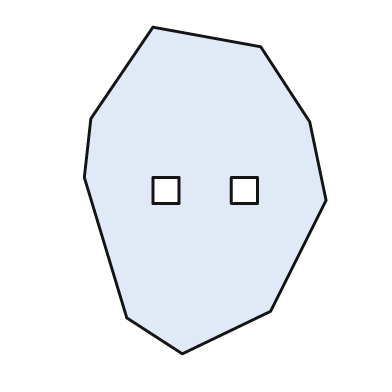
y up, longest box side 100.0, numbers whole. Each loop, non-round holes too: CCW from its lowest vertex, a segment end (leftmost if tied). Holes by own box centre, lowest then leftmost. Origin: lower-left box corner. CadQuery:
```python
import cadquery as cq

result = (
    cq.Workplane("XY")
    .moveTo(30.0, 0.0)
    .lineTo(57.0, 13.0)
    .lineTo(74.0, 47.0)
    .lineTo(69.0, 71.0)
    .lineTo(54.0, 94.0)
    .lineTo(21.0, 100.0)
    .lineTo(2.0, 72.0)
    .lineTo(0.0, 54.0)
    .lineTo(13.0, 11.0)
    .close()
    .moveTo(21.0, 46.0)
    .lineTo(29.0, 46.0)
    .lineTo(29.0, 54.0)
    .lineTo(21.0, 54.0)
    .close()
    .moveTo(45.0, 46.0)
    .lineTo(53.0, 46.0)
    .lineTo(53.0, 54.0)
    .lineTo(45.0, 54.0)
    .close()
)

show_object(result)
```